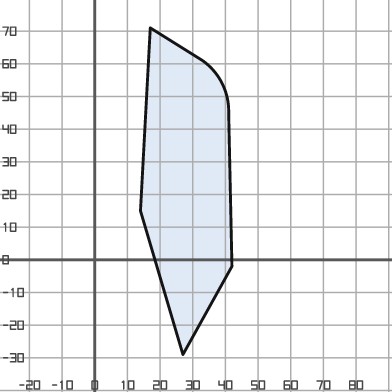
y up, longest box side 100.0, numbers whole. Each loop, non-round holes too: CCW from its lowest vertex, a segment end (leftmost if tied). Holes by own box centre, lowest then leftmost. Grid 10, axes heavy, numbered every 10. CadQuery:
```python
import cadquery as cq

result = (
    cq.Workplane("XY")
    .moveTo(27.0, -29.0)
    .lineTo(42.0, -2.0)
    .lineTo(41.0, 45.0)
    .threePointArc((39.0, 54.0), (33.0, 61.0))
    .lineTo(17.0, 71.0)
    .lineTo(14.0, 15.0)
    .close()
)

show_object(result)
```